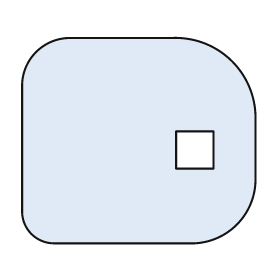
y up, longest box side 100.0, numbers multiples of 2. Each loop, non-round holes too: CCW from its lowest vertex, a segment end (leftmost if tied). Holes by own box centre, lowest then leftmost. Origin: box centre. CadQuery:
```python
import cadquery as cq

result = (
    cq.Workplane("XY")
    .moveTo(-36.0, -44.0)
    .lineTo(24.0, -44.0)
    .threePointArc((42.0, -36.0), (50.0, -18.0))
    .lineTo(50.0, 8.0)
    .threePointArc((40.0, 34.0), (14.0, 44.0))
    .lineTo(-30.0, 44.0)
    .threePointArc((-44.0, 38.0), (-50.0, 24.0))
    .lineTo(-50.0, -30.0)
    .threePointArc((-46.0, -40.0), (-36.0, -44.0))
    .close()
    .moveTo(16.0, -12.0)
    .lineTo(32.0, -12.0)
    .lineTo(32.0, 4.0)
    .lineTo(16.0, 4.0)
    .close()
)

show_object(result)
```